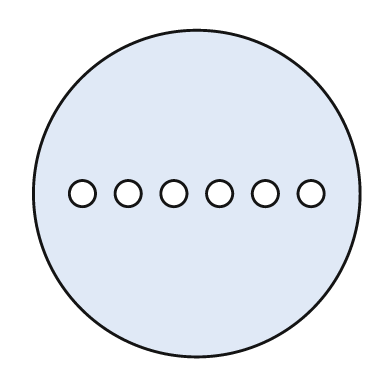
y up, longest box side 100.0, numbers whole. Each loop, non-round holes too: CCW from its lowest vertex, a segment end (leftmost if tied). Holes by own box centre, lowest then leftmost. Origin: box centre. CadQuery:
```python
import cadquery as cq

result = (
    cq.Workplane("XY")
    .moveTo(0.0, 0.0)
    .circle(50.0)
    .moveTo(-35.0, 0.0)
    .circle(4.0)
    .moveTo(-21.0, 0.0)
    .circle(4.0)
    .moveTo(-7.0, 0.0)
    .circle(4.0)
    .moveTo(7.0, 0.0)
    .circle(4.0)
    .moveTo(21.0, 0.0)
    .circle(4.0)
    .moveTo(35.0, 0.0)
    .circle(4.0)
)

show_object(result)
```